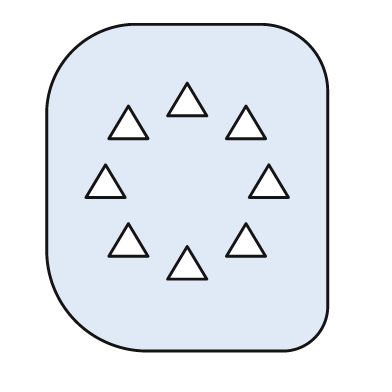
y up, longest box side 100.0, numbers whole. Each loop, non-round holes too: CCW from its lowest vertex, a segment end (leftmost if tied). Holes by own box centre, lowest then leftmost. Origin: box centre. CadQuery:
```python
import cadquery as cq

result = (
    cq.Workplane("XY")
    .moveTo(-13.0, -50.0)
    .lineTo(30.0, -50.0)
    .threePointArc((39.0, -46.0), (43.0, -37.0))
    .lineTo(43.0, 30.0)
    .threePointArc((37.0, 44.0), (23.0, 50.0))
    .lineTo(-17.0, 50.0)
    .threePointArc((-35.0, 42.0), (-43.0, 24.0))
    .lineTo(-43.0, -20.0)
    .threePointArc((-34.0, -41.0), (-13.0, -50.0))
    .close()
    .moveTo(-6.0, -28.0)
    .lineTo(6.0, -28.0)
    .lineTo(0.0, -18.0)
    .close()
    .moveTo(-24.0, -21.0)
    .lineTo(-12.0, -21.0)
    .lineTo(-18.0, -11.0)
    .close()
    .moveTo(12.0, -21.0)
    .lineTo(24.0, -21.0)
    .lineTo(18.0, -11.0)
    .close()
    .moveTo(-31.0, -3.0)
    .lineTo(-19.0, -3.0)
    .lineTo(-25.0, 7.0)
    .close()
    .moveTo(19.0, -3.0)
    .lineTo(31.0, -3.0)
    .lineTo(25.0, 7.0)
    .close()
    .moveTo(-24.0, 15.0)
    .lineTo(-12.0, 15.0)
    .lineTo(-18.0, 25.0)
    .close()
    .moveTo(12.0, 15.0)
    .lineTo(24.0, 15.0)
    .lineTo(18.0, 25.0)
    .close()
    .moveTo(-6.0, 22.0)
    .lineTo(6.0, 22.0)
    .lineTo(0.0, 32.0)
    .close()
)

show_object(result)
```